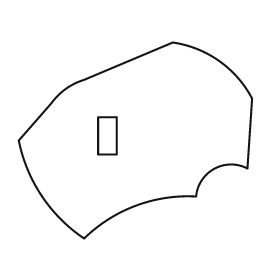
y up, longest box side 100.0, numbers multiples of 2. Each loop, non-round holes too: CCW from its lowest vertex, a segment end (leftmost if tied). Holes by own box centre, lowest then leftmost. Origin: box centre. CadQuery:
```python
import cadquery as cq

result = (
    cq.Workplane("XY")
    .moveTo(-22.0, -42.0)
    .threePointArc((0.0, -28.0), (26.0, -24.0))
    .threePointArc((34.0, -12.0), (48.0, -12.0))
    .lineTo(50.0, 18.0)
    .threePointArc((36.0, 34.0), (16.0, 42.0))
    .lineTo(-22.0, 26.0)
    .threePointArc((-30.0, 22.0), (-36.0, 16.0))
    .lineTo(-50.0, 0.0)
    .threePointArc((-40.0, -24.0), (-22.0, -42.0))
    .close()
    .moveTo(-16.0, -6.0)
    .lineTo(-8.0, -6.0)
    .lineTo(-8.0, 10.0)
    .lineTo(-16.0, 10.0)
    .close()
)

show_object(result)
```